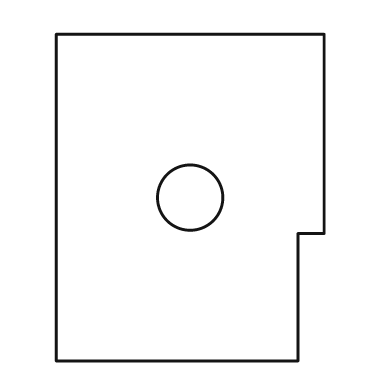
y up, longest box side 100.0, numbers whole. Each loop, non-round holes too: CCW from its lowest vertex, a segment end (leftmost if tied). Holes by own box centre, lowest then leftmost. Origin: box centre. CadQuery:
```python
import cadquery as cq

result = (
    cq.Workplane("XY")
    .moveTo(-41.0, -50.0)
    .lineTo(33.0, -50.0)
    .lineTo(33.0, -11.0)
    .lineTo(41.0, -11.0)
    .lineTo(41.0, 50.0)
    .lineTo(-41.0, 50.0)
    .close()
    .moveTo(0.0, 0.0)
    .circle(10.0)
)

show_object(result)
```